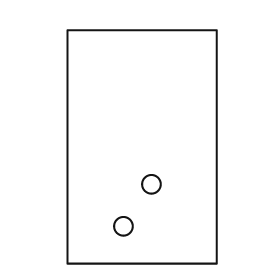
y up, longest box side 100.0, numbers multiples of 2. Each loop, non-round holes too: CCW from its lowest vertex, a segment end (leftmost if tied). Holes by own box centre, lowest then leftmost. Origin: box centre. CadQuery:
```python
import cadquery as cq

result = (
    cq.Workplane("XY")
    .moveTo(-32.0, -50.0)
    .lineTo(32.0, -50.0)
    .lineTo(32.0, 50.0)
    .lineTo(-32.0, 50.0)
    .close()
    .moveTo(-8.0, -34.0)
    .circle(4.0)
    .moveTo(4.0, -16.0)
    .circle(4.0)
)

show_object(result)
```